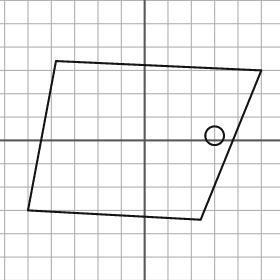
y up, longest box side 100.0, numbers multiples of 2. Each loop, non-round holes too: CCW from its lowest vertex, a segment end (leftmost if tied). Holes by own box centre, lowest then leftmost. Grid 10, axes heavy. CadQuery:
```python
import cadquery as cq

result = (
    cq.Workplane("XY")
    .moveTo(24.0, -34.0)
    .lineTo(50.0, 30.0)
    .lineTo(-38.0, 34.0)
    .lineTo(-50.0, -30.0)
    .close()
    .moveTo(30.0, 2.0)
    .circle(4.0)
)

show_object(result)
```